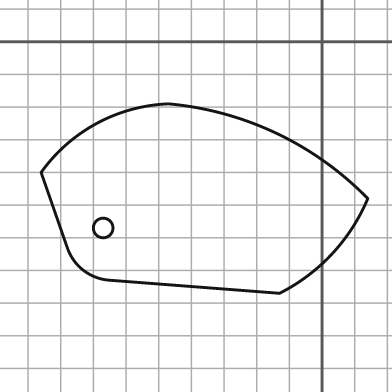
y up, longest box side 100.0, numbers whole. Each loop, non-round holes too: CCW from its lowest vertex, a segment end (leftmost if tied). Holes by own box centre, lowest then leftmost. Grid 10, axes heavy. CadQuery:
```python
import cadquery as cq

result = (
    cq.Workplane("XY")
    .moveTo(-13.0, -77.0)
    .threePointArc((3.0, -65.0), (14.0, -48.0))
    .threePointArc((-14.0, -28.0), (-47.0, -19.0))
    .threePointArc((-69.0, -25.0), (-86.0, -40.0))
    .lineTo(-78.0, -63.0)
    .threePointArc((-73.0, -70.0), (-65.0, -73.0))
    .close()
    .moveTo(-67.0, -57.0)
    .circle(3.0)
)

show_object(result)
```